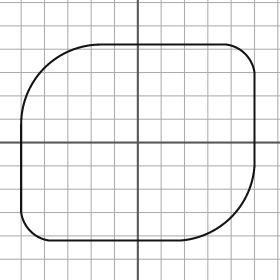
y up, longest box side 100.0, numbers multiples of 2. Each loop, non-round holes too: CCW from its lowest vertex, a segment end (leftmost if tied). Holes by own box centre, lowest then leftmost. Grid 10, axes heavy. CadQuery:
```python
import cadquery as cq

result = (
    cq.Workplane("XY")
    .moveTo(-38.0, -42.0)
    .lineTo(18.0, -42.0)
    .threePointArc((40.0, -32.0), (50.0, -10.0))
    .lineTo(50.0, 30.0)
    .threePointArc((46.0, 38.0), (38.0, 42.0))
    .lineTo(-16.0, 42.0)
    .threePointArc((-40.0, 32.0), (-50.0, 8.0))
    .lineTo(-50.0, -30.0)
    .threePointArc((-46.0, -38.0), (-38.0, -42.0))
    .close()
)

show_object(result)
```